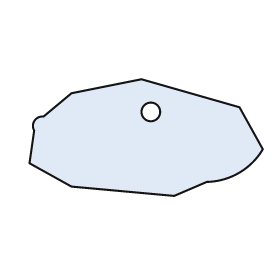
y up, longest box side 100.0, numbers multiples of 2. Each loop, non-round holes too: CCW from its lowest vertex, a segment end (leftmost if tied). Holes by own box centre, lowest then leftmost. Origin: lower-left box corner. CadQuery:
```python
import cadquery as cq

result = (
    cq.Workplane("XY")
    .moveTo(62.0, 0.0)
    .lineTo(76.0, 6.0)
    .threePointArc((90.0, 10.0), (100.0, 20.0))
    .lineTo(90.0, 38.0)
    .lineTo(48.0, 50.0)
    .lineTo(18.0, 44.0)
    .lineTo(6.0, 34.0)
    .threePointArc((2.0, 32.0), (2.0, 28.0))
    .lineTo(0.0, 14.0)
    .lineTo(18.0, 4.0)
    .close()
    .moveTo(52.0, 36.0)
    .circle(4.0)
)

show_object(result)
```